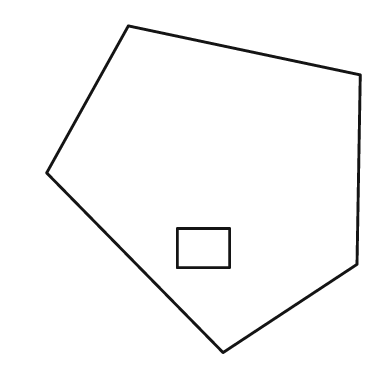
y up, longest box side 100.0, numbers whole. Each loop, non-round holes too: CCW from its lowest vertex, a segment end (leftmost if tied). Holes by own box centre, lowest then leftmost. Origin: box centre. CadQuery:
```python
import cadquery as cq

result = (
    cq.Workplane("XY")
    .moveTo(6.0, -50.0)
    .lineTo(47.0, -23.0)
    .lineTo(48.0, 35.0)
    .lineTo(-23.0, 50.0)
    .lineTo(-48.0, 5.0)
    .close()
    .moveTo(-8.0, -24.0)
    .lineTo(8.0, -24.0)
    .lineTo(8.0, -12.0)
    .lineTo(-8.0, -12.0)
    .close()
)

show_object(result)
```